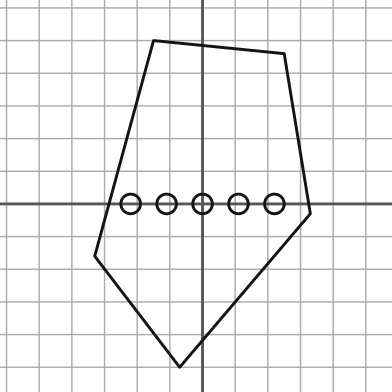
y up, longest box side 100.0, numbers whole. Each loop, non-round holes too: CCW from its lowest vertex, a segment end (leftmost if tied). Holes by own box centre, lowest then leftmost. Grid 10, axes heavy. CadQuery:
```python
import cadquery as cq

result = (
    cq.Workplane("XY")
    .moveTo(-7.0, -50.0)
    .lineTo(33.0, -3.0)
    .lineTo(25.0, 46.0)
    .lineTo(-15.0, 50.0)
    .lineTo(-33.0, -16.0)
    .close()
    .moveTo(-22.0, 0.0)
    .circle(3.0)
    .moveTo(-11.0, 0.0)
    .circle(3.0)
    .moveTo(0.0, 0.0)
    .circle(3.0)
    .moveTo(11.0, 0.0)
    .circle(3.0)
    .moveTo(22.0, 0.0)
    .circle(3.0)
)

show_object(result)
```